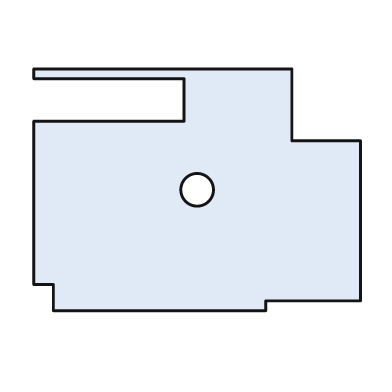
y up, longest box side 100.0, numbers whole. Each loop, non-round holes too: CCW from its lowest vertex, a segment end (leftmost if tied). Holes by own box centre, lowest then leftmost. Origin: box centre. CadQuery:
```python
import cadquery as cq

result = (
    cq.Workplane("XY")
    .moveTo(-44.0, -37.0)
    .lineTo(21.0, -37.0)
    .lineTo(21.0, -34.0)
    .lineTo(50.0, -34.0)
    .lineTo(50.0, 15.0)
    .lineTo(29.0, 15.0)
    .lineTo(29.0, 37.0)
    .lineTo(-50.0, 37.0)
    .lineTo(-50.0, 34.0)
    .lineTo(-4.0, 34.0)
    .lineTo(-4.0, 21.0)
    .lineTo(-50.0, 21.0)
    .lineTo(-50.0, -29.0)
    .lineTo(-44.0, -29.0)
    .close()
    .moveTo(0.0, 0.0)
    .circle(5.0)
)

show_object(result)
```